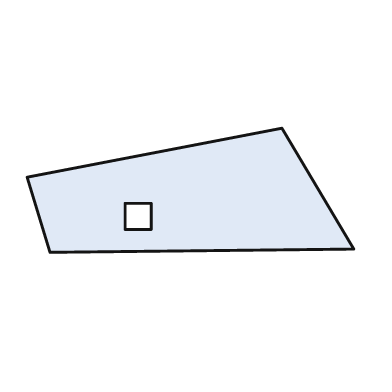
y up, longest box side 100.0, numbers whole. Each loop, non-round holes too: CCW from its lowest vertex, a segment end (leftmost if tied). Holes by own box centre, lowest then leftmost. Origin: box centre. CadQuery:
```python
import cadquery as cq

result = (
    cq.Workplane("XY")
    .moveTo(-43.0, -19.0)
    .lineTo(50.0, -18.0)
    .lineTo(28.0, 19.0)
    .lineTo(-50.0, 4.0)
    .close()
    .moveTo(-20.0, -12.0)
    .lineTo(-12.0, -12.0)
    .lineTo(-12.0, -4.0)
    .lineTo(-20.0, -4.0)
    .close()
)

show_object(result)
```